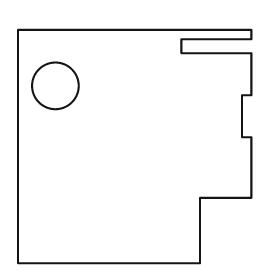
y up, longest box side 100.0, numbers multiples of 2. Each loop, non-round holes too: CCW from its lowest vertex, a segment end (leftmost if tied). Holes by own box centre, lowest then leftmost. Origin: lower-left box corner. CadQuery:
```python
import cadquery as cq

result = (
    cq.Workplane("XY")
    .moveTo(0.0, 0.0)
    .lineTo(78.0, 0.0)
    .lineTo(78.0, 28.0)
    .lineTo(100.0, 28.0)
    .lineTo(100.0, 54.0)
    .lineTo(96.0, 54.0)
    .lineTo(96.0, 72.0)
    .lineTo(100.0, 72.0)
    .lineTo(100.0, 90.0)
    .lineTo(70.0, 90.0)
    .lineTo(70.0, 96.0)
    .lineTo(100.0, 96.0)
    .lineTo(100.0, 100.0)
    .lineTo(0.0, 100.0)
    .close()
    .moveTo(16.0, 76.0)
    .circle(10.0)
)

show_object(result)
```